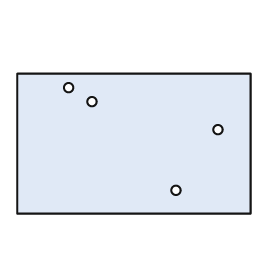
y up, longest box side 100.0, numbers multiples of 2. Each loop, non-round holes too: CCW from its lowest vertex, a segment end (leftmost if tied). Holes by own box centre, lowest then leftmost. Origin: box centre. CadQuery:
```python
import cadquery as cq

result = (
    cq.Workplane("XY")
    .moveTo(-50.0, -30.0)
    .lineTo(50.0, -30.0)
    .lineTo(50.0, 30.0)
    .lineTo(-50.0, 30.0)
    .close()
    .moveTo(18.0, -20.0)
    .circle(2.0)
    .moveTo(36.0, 6.0)
    .circle(2.0)
    .moveTo(-18.0, 18.0)
    .circle(2.0)
    .moveTo(-28.0, 24.0)
    .circle(2.0)
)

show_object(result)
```